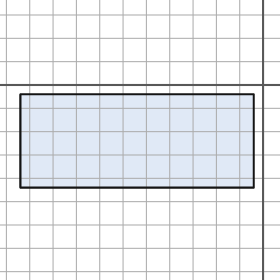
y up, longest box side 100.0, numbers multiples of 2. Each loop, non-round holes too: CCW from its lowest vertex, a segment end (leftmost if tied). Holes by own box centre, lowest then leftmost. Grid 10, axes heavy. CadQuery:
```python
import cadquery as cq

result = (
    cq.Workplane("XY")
    .moveTo(-104.0, -44.0)
    .lineTo(-4.0, -44.0)
    .lineTo(-4.0, -4.0)
    .lineTo(-104.0, -4.0)
    .close()
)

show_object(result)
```